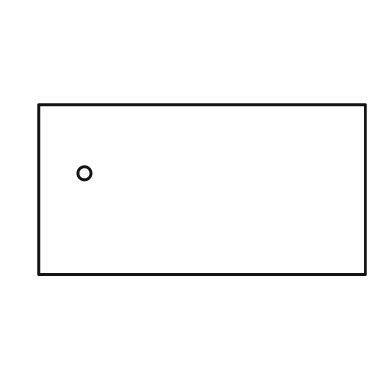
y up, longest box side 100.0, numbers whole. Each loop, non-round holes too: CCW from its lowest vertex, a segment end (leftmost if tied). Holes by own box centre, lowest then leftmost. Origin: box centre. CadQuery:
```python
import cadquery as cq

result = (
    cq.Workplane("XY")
    .moveTo(-50.0, -26.0)
    .lineTo(50.0, -26.0)
    .lineTo(50.0, 26.0)
    .lineTo(-50.0, 26.0)
    .close()
    .moveTo(-36.0, 5.0)
    .circle(2.0)
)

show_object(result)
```